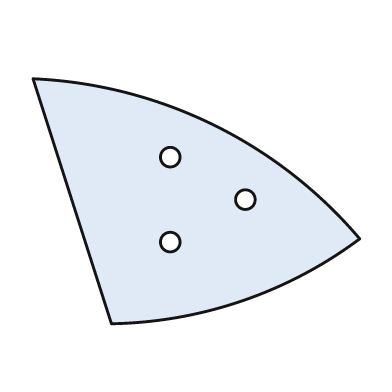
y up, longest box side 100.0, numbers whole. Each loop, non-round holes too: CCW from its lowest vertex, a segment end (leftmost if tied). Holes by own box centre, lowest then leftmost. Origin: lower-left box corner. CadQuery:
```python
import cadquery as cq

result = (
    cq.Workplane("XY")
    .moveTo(24.0, 0.0)
    .threePointArc((64.0, 7.0), (100.0, 26.0))
    .threePointArc((55.0, 61.0), (0.0, 75.0))
    .close()
    .moveTo(42.0, 25.0)
    .circle(3.0)
    .moveTo(65.0, 38.0)
    .circle(3.0)
    .moveTo(42.0, 51.0)
    .circle(3.0)
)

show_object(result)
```